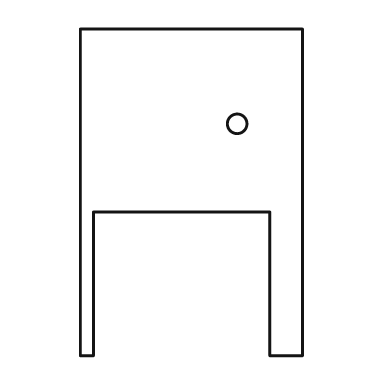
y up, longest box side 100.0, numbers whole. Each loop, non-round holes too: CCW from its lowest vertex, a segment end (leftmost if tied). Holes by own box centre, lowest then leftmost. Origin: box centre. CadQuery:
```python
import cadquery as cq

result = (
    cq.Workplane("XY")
    .moveTo(-34.0, -50.0)
    .lineTo(-30.0, -50.0)
    .lineTo(-30.0, -6.0)
    .lineTo(24.0, -6.0)
    .lineTo(24.0, -50.0)
    .lineTo(34.0, -50.0)
    .lineTo(34.0, 50.0)
    .lineTo(-34.0, 50.0)
    .close()
    .moveTo(14.0, 21.0)
    .circle(3.0)
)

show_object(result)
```